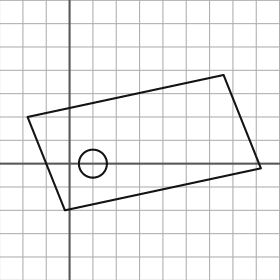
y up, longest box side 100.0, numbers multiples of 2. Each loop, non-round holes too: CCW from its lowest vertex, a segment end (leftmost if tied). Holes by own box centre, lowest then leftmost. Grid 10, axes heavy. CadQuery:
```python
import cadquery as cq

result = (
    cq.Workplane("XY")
    .moveTo(-2.0, -20.0)
    .lineTo(82.0, -2.0)
    .lineTo(66.0, 38.0)
    .lineTo(-18.0, 20.0)
    .close()
    .moveTo(10.0, 0.0)
    .circle(6.0)
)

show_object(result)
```